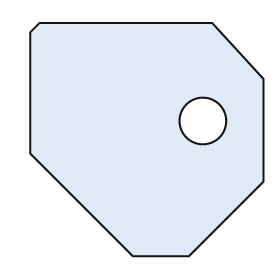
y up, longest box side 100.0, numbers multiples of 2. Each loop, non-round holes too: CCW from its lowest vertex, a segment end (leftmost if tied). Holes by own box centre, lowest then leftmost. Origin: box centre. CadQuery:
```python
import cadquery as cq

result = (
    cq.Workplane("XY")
    .moveTo(-6.0, -50.0)
    .lineTo(18.0, -50.0)
    .lineTo(50.0, -18.0)
    .lineTo(50.0, 26.0)
    .lineTo(28.0, 50.0)
    .lineTo(-46.0, 50.0)
    .lineTo(-50.0, 46.0)
    .lineTo(-50.0, -6.0)
    .close()
    .moveTo(24.0, 8.0)
    .circle(10.0)
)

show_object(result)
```